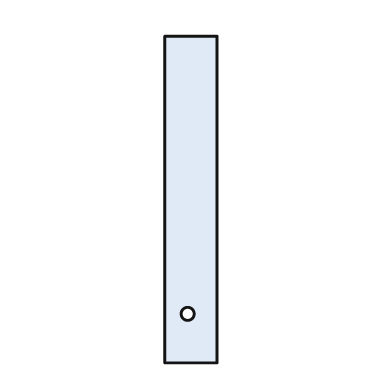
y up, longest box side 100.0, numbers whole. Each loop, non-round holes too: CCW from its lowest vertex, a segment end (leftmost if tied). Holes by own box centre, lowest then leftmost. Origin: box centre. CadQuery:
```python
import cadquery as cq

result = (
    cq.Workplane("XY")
    .moveTo(-8.0, -50.0)
    .lineTo(8.0, -50.0)
    .lineTo(8.0, 50.0)
    .lineTo(-8.0, 50.0)
    .close()
    .moveTo(-1.0, -35.0)
    .circle(2.0)
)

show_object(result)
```